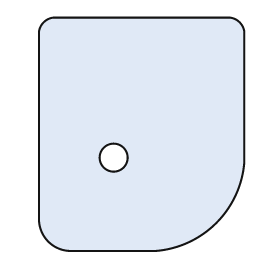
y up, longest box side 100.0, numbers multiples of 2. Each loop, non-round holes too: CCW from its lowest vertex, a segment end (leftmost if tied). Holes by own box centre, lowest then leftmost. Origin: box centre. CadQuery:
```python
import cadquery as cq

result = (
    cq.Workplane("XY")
    .moveTo(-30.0, -50.0)
    .lineTo(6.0, -50.0)
    .threePointArc((32.0, -38.0), (44.0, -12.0))
    .lineTo(44.0, 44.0)
    .threePointArc((42.0, 48.0), (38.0, 50.0))
    .lineTo(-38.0, 50.0)
    .threePointArc((-42.0, 48.0), (-44.0, 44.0))
    .lineTo(-44.0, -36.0)
    .threePointArc((-40.0, -46.0), (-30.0, -50.0))
    .close()
    .moveTo(-12.0, -10.0)
    .circle(6.0)
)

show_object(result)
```